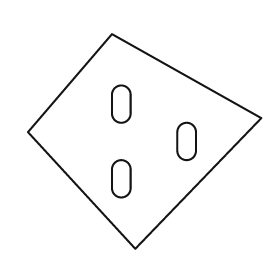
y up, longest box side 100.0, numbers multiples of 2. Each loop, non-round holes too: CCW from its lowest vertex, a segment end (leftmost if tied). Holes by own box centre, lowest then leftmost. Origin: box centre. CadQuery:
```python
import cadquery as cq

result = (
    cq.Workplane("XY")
    .moveTo(-4.0, -46.0)
    .lineTo(50.0, 10.0)
    .lineTo(-14.0, 46.0)
    .lineTo(-50.0, 4.0)
    .close()
    .moveTo(-14.0, -20.0)
    .threePointArc((-10.0, -24.0), (-6.0, -20.0))
    .lineTo(-6.0, -12.0)
    .threePointArc((-10.0, -8.0), (-14.0, -12.0))
    .close()
    .moveTo(14.0, -4.0)
    .threePointArc((18.0, -8.0), (22.0, -4.0))
    .lineTo(22.0, 4.0)
    .threePointArc((18.0, 8.0), (14.0, 4.0))
    .close()
    .moveTo(-14.0, 12.0)
    .threePointArc((-10.0, 8.0), (-6.0, 12.0))
    .lineTo(-6.0, 20.0)
    .threePointArc((-10.0, 24.0), (-14.0, 20.0))
    .close()
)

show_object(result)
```